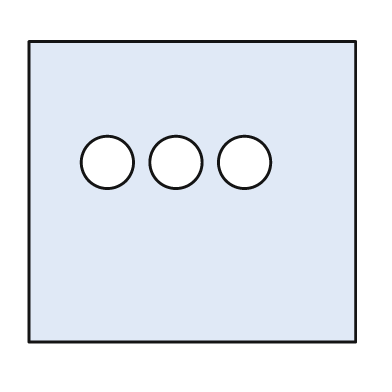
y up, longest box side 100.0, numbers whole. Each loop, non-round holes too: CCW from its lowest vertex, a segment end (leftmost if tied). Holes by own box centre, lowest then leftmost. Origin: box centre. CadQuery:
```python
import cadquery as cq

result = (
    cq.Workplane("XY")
    .moveTo(-50.0, -46.0)
    .lineTo(50.0, -46.0)
    .lineTo(50.0, 46.0)
    .lineTo(-50.0, 46.0)
    .close()
    .moveTo(-26.0, 9.0)
    .circle(8.0)
    .moveTo(-5.0, 9.0)
    .circle(8.0)
    .moveTo(16.0, 9.0)
    .circle(8.0)
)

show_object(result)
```